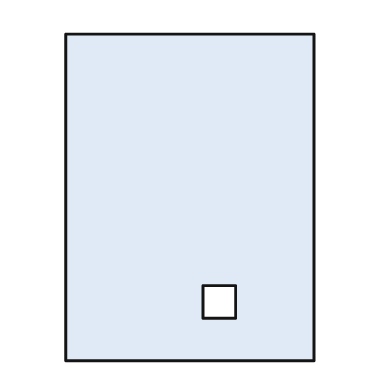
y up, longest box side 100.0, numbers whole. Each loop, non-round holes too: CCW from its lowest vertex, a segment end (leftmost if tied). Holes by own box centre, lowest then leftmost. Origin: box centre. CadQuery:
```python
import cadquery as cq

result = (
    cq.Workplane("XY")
    .moveTo(-38.0, -50.0)
    .lineTo(38.0, -50.0)
    .lineTo(38.0, 50.0)
    .lineTo(-38.0, 50.0)
    .close()
    .moveTo(4.0, -37.0)
    .lineTo(14.0, -37.0)
    .lineTo(14.0, -27.0)
    .lineTo(4.0, -27.0)
    .close()
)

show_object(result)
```